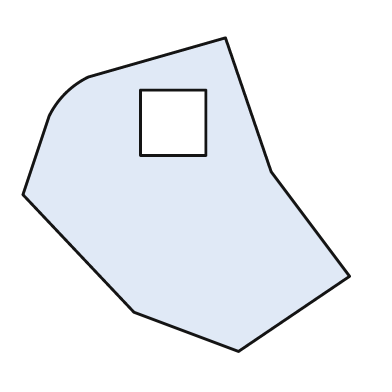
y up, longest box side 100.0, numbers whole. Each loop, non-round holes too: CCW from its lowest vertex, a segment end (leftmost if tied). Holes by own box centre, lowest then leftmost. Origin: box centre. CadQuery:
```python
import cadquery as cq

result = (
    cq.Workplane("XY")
    .moveTo(16.0, -48.0)
    .lineTo(50.0, -25.0)
    .lineTo(26.0, 7.0)
    .lineTo(12.0, 48.0)
    .lineTo(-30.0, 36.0)
    .threePointArc((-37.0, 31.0), (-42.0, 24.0))
    .lineTo(-50.0, 0.0)
    .lineTo(-16.0, -36.0)
    .close()
    .moveTo(-14.0, 12.0)
    .lineTo(6.0, 12.0)
    .lineTo(6.0, 32.0)
    .lineTo(-14.0, 32.0)
    .close()
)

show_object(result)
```